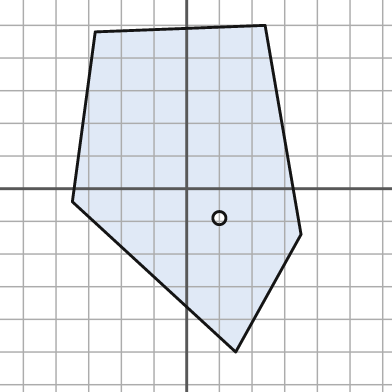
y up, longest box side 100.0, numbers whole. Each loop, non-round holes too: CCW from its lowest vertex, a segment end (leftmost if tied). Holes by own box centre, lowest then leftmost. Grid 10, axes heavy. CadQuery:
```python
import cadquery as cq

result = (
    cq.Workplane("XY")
    .moveTo(15.0, -50.0)
    .lineTo(35.0, -14.0)
    .lineTo(24.0, 50.0)
    .lineTo(-28.0, 48.0)
    .lineTo(-35.0, -4.0)
    .close()
    .moveTo(10.0, -9.0)
    .circle(2.0)
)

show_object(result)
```